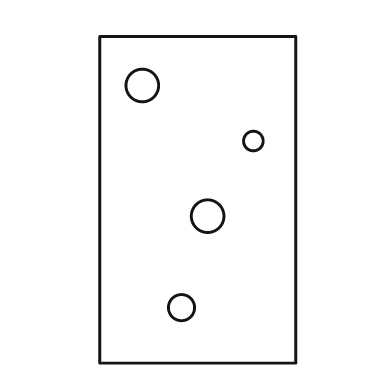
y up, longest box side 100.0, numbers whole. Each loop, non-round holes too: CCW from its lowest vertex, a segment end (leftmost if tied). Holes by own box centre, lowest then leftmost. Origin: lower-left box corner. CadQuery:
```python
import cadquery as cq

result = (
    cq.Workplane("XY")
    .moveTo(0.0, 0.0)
    .lineTo(60.0, 0.0)
    .lineTo(60.0, 100.0)
    .lineTo(0.0, 100.0)
    .close()
    .moveTo(25.0, 17.0)
    .circle(4.0)
    .moveTo(33.0, 45.0)
    .circle(5.0)
    .moveTo(47.0, 68.0)
    .circle(3.0)
    .moveTo(13.0, 85.0)
    .circle(5.0)
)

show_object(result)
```